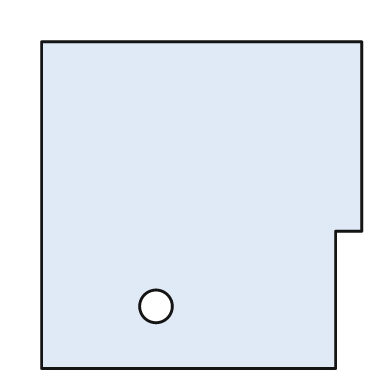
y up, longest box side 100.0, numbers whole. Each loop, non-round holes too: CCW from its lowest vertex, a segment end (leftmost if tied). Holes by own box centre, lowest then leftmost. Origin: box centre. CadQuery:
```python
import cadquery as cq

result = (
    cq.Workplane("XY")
    .moveTo(-49.0, -50.0)
    .lineTo(41.0, -50.0)
    .lineTo(41.0, -8.0)
    .lineTo(49.0, -8.0)
    .lineTo(49.0, 50.0)
    .lineTo(-49.0, 50.0)
    .close()
    .moveTo(-14.0, -31.0)
    .circle(5.0)
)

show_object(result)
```